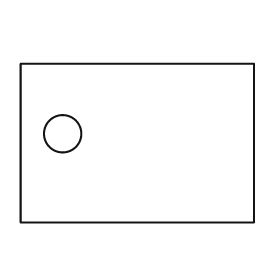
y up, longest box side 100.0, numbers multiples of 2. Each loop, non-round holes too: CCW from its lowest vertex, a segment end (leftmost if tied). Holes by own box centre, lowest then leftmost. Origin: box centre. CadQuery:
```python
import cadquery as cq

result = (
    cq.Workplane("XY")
    .moveTo(-50.0, -34.0)
    .lineTo(50.0, -34.0)
    .lineTo(50.0, 34.0)
    .lineTo(-50.0, 34.0)
    .close()
    .moveTo(-32.0, 4.0)
    .circle(8.0)
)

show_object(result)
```